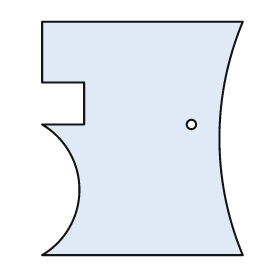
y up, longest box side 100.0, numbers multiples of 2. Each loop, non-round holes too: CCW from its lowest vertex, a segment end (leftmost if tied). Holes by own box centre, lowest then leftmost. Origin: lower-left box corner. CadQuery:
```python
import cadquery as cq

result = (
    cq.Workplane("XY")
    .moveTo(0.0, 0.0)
    .lineTo(86.0, 0.0)
    .threePointArc((76.0, 50.0), (86.0, 100.0))
    .lineTo(0.0, 100.0)
    .lineTo(0.0, 74.0)
    .lineTo(18.0, 74.0)
    .lineTo(18.0, 56.0)
    .lineTo(0.0, 56.0)
    .threePointArc((16.0, 28.0), (0.0, 0.0))
    .close()
    .moveTo(64.0, 56.0)
    .circle(2.0)
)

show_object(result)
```